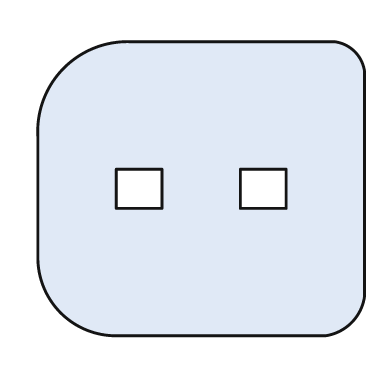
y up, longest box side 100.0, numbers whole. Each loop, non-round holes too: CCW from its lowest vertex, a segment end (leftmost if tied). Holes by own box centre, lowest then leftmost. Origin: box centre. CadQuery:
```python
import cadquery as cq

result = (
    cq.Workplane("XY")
    .moveTo(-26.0, -45.0)
    .lineTo(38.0, -45.0)
    .threePointArc((46.0, -41.0), (50.0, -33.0))
    .lineTo(50.0, 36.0)
    .threePointArc((47.0, 42.0), (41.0, 45.0))
    .lineTo(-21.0, 45.0)
    .threePointArc((-42.0, 37.0), (-50.0, 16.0))
    .lineTo(-50.0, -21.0)
    .threePointArc((-43.0, -38.0), (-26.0, -45.0))
    .close()
    .moveTo(-26.0, -6.0)
    .lineTo(-12.0, -6.0)
    .lineTo(-12.0, 6.0)
    .lineTo(-26.0, 6.0)
    .close()
    .moveTo(12.0, -6.0)
    .lineTo(26.0, -6.0)
    .lineTo(26.0, 6.0)
    .lineTo(12.0, 6.0)
    .close()
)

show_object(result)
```